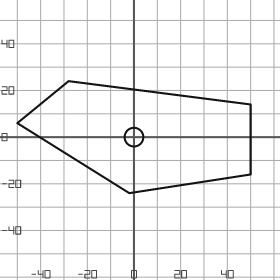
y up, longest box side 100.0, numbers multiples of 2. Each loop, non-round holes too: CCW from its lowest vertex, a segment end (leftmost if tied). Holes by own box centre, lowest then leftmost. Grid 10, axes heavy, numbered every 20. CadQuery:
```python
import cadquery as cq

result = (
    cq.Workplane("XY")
    .moveTo(-2.0, -24.0)
    .lineTo(50.0, -16.0)
    .lineTo(50.0, 14.0)
    .lineTo(-28.0, 24.0)
    .lineTo(-50.0, 6.0)
    .close()
    .moveTo(0.0, 0.0)
    .circle(4.0)
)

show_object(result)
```